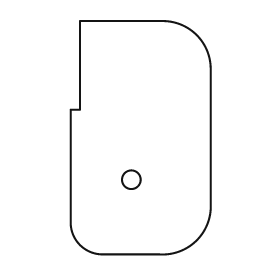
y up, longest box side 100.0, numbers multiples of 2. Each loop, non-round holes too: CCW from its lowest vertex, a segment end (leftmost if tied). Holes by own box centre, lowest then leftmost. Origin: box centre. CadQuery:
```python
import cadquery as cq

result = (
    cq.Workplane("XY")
    .moveTo(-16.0, -50.0)
    .lineTo(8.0, -50.0)
    .threePointArc((24.0, -44.0), (30.0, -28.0))
    .lineTo(30.0, 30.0)
    .threePointArc((24.0, 44.0), (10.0, 50.0))
    .lineTo(-26.0, 50.0)
    .lineTo(-26.0, 12.0)
    .lineTo(-30.0, 12.0)
    .lineTo(-30.0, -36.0)
    .threePointArc((-26.0, -46.0), (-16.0, -50.0))
    .close()
    .moveTo(-4.0, -18.0)
    .circle(4.0)
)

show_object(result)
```